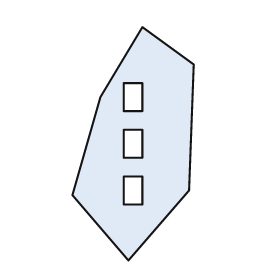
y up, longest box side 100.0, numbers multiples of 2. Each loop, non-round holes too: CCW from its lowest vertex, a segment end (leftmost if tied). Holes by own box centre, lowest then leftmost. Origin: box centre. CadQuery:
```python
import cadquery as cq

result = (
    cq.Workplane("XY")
    .moveTo(-2.0, -50.0)
    .lineTo(24.0, -20.0)
    .lineTo(26.0, 34.0)
    .lineTo(4.0, 50.0)
    .lineTo(-14.0, 20.0)
    .lineTo(-26.0, -22.0)
    .close()
    .moveTo(-4.0, -26.0)
    .lineTo(4.0, -26.0)
    .lineTo(4.0, -14.0)
    .lineTo(-4.0, -14.0)
    .close()
    .moveTo(-4.0, -6.0)
    .lineTo(4.0, -6.0)
    .lineTo(4.0, 6.0)
    .lineTo(-4.0, 6.0)
    .close()
    .moveTo(-4.0, 14.0)
    .lineTo(4.0, 14.0)
    .lineTo(4.0, 26.0)
    .lineTo(-4.0, 26.0)
    .close()
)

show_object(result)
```